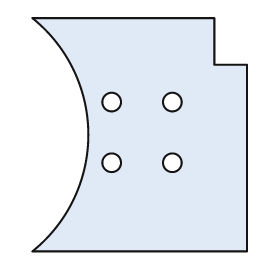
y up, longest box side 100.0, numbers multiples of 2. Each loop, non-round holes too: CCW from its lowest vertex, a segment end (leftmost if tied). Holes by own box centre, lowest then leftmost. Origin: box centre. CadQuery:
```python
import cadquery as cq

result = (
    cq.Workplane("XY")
    .moveTo(-46.0, -50.0)
    .lineTo(46.0, -50.0)
    .lineTo(46.0, 30.0)
    .lineTo(32.0, 30.0)
    .lineTo(32.0, 50.0)
    .lineTo(-46.0, 50.0)
    .threePointArc((-22.0, 0.0), (-46.0, -50.0))
    .close()
    .moveTo(-12.0, -12.0)
    .circle(4.0)
    .moveTo(14.0, -12.0)
    .circle(4.0)
    .moveTo(-12.0, 14.0)
    .circle(4.0)
    .moveTo(14.0, 14.0)
    .circle(4.0)
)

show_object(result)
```